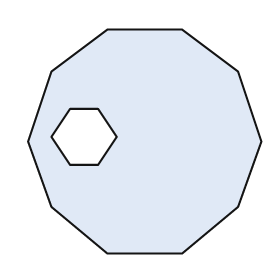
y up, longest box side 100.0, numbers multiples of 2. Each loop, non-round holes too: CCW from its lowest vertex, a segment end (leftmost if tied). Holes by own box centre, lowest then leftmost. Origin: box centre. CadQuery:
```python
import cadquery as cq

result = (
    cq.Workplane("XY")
    .moveTo(-16.0, -48.0)
    .lineTo(16.0, -48.0)
    .lineTo(40.0, -28.0)
    .lineTo(50.0, 0.0)
    .lineTo(40.0, 30.0)
    .lineTo(16.0, 48.0)
    .lineTo(-16.0, 48.0)
    .lineTo(-40.0, 30.0)
    .lineTo(-50.0, 0.0)
    .lineTo(-40.0, -28.0)
    .close()
    .moveTo(-32.0, -10.0)
    .lineTo(-20.0, -10.0)
    .lineTo(-12.0, 2.0)
    .lineTo(-20.0, 14.0)
    .lineTo(-32.0, 14.0)
    .lineTo(-40.0, 2.0)
    .close()
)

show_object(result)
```